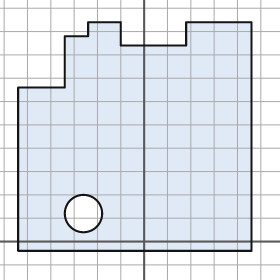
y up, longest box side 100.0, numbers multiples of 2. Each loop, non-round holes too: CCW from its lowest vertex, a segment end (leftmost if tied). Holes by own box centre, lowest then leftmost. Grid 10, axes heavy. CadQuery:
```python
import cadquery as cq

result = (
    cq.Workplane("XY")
    .moveTo(-54.0, -4.0)
    .lineTo(46.0, -4.0)
    .lineTo(46.0, 94.0)
    .lineTo(18.0, 94.0)
    .lineTo(18.0, 84.0)
    .lineTo(-10.0, 84.0)
    .lineTo(-10.0, 94.0)
    .lineTo(-24.0, 94.0)
    .lineTo(-24.0, 88.0)
    .lineTo(-34.0, 88.0)
    .lineTo(-34.0, 66.0)
    .lineTo(-54.0, 66.0)
    .close()
    .moveTo(-26.0, 12.0)
    .circle(8.0)
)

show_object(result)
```